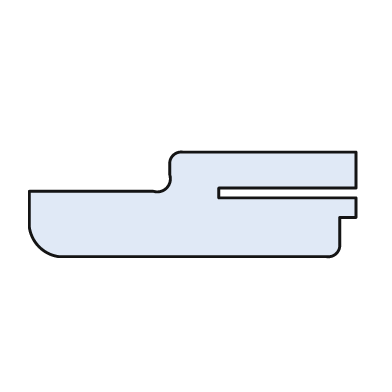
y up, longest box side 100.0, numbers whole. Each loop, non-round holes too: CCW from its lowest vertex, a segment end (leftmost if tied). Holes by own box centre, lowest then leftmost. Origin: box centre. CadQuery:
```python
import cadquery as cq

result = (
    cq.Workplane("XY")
    .moveTo(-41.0, -16.0)
    .lineTo(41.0, -16.0)
    .threePointArc((44.0, -15.0), (45.0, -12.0))
    .lineTo(45.0, -4.0)
    .lineTo(50.0, -4.0)
    .lineTo(50.0, 2.0)
    .lineTo(8.0, 2.0)
    .lineTo(8.0, 5.0)
    .lineTo(50.0, 5.0)
    .lineTo(50.0, 16.0)
    .lineTo(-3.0, 16.0)
    .threePointArc((-6.0, 15.0), (-7.0, 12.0))
    .lineTo(-7.0, 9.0)
    .threePointArc((-8.0, 5.0), (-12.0, 4.0))
    .lineTo(-50.0, 4.0)
    .lineTo(-50.0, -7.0)
    .threePointArc((-47.0, -13.0), (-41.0, -16.0))
    .close()
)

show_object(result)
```